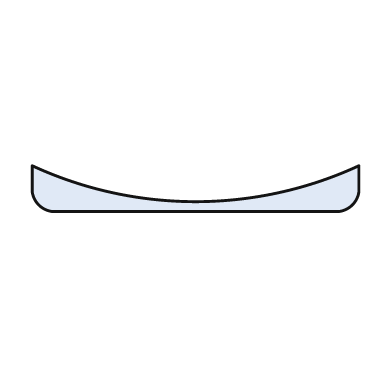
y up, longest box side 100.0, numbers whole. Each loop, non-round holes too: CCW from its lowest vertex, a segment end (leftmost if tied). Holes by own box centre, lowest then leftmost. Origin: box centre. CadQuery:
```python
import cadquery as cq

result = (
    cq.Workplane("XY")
    .moveTo(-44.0, -7.0)
    .lineTo(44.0, -7.0)
    .threePointArc((48.0, -5.0), (50.0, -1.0))
    .lineTo(50.0, 7.0)
    .threePointArc((0.0, -4.0), (-50.0, 7.0))
    .lineTo(-50.0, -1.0)
    .threePointArc((-48.0, -5.0), (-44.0, -7.0))
    .close()
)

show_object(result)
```